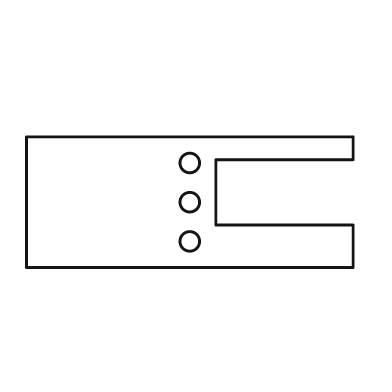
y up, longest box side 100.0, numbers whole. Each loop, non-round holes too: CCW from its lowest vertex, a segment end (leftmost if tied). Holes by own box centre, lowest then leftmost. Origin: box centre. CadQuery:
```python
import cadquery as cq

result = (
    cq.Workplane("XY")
    .moveTo(-50.0, -20.0)
    .lineTo(50.0, -20.0)
    .lineTo(50.0, -7.0)
    .lineTo(8.0, -7.0)
    .lineTo(8.0, 13.0)
    .lineTo(50.0, 13.0)
    .lineTo(50.0, 20.0)
    .lineTo(-50.0, 20.0)
    .close()
    .moveTo(0.0, -12.0)
    .circle(3.0)
    .moveTo(0.0, 0.0)
    .circle(3.0)
    .moveTo(0.0, 12.0)
    .circle(3.0)
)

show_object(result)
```